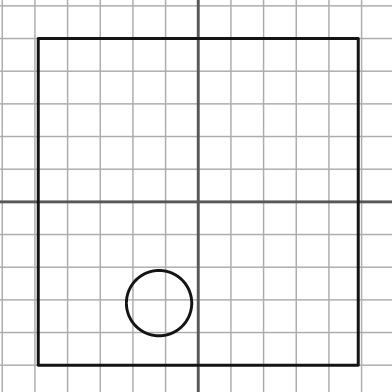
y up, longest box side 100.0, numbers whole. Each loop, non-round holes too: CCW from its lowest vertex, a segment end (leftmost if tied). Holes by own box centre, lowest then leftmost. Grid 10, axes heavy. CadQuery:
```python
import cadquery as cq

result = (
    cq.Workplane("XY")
    .moveTo(-49.0, -50.0)
    .lineTo(49.0, -50.0)
    .lineTo(49.0, 50.0)
    .lineTo(-49.0, 50.0)
    .close()
    .moveTo(-12.0, -31.0)
    .circle(10.0)
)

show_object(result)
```